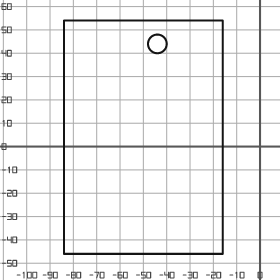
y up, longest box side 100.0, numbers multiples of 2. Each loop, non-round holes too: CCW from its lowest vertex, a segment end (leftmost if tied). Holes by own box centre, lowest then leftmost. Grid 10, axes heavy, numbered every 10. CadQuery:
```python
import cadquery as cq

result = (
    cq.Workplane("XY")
    .moveTo(-84.0, -46.0)
    .lineTo(-16.0, -46.0)
    .lineTo(-16.0, 54.0)
    .lineTo(-84.0, 54.0)
    .close()
    .moveTo(-44.0, 44.0)
    .circle(4.0)
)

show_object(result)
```